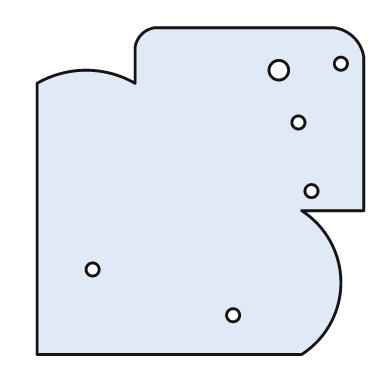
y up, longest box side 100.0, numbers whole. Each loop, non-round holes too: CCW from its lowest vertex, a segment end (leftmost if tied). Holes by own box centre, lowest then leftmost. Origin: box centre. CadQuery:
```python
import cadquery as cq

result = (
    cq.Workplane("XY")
    .moveTo(-50.0, -50.0)
    .lineTo(31.0, -50.0)
    .threePointArc((43.0, -28.0), (31.0, -6.0))
    .lineTo(50.0, -6.0)
    .lineTo(50.0, 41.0)
    .threePointArc((47.0, 47.0), (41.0, 50.0))
    .lineTo(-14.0, 50.0)
    .threePointArc((-18.0, 48.0), (-20.0, 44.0))
    .lineTo(-20.0, 33.0)
    .threePointArc((-35.0, 37.0), (-50.0, 33.0))
    .close()
    .moveTo(10.0, -38.0)
    .circle(2.0)
    .moveTo(-33.0, -24.0)
    .circle(2.0)
    .moveTo(34.0, 0.0)
    .circle(2.0)
    .moveTo(30.0, 21.0)
    .circle(2.0)
    .moveTo(24.0, 37.0)
    .circle(3.0)
    .moveTo(43.0, 39.0)
    .circle(2.0)
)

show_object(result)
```